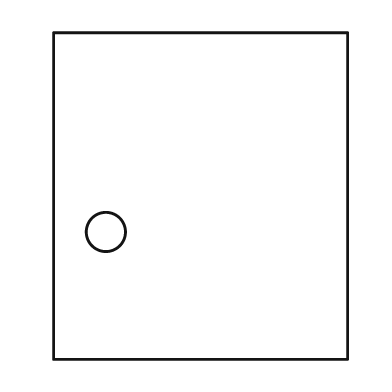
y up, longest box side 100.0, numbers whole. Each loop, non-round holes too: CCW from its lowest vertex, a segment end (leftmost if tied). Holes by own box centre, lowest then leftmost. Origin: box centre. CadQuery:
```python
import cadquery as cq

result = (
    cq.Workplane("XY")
    .moveTo(-45.0, -50.0)
    .lineTo(45.0, -50.0)
    .lineTo(45.0, 50.0)
    .lineTo(-45.0, 50.0)
    .close()
    .moveTo(-29.0, -11.0)
    .circle(6.0)
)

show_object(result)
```